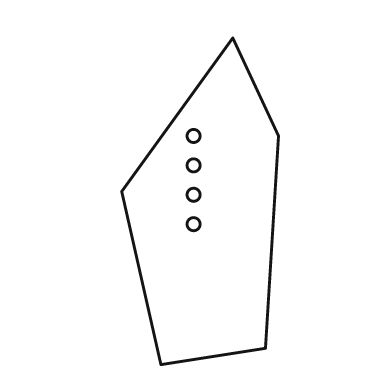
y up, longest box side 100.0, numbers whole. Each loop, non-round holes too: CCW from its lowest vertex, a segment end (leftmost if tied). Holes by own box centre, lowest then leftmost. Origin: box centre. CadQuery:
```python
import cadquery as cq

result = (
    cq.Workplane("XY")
    .moveTo(-12.0, -50.0)
    .lineTo(20.0, -45.0)
    .lineTo(24.0, 20.0)
    .lineTo(10.0, 50.0)
    .lineTo(-24.0, 3.0)
    .close()
    .moveTo(-2.0, -7.0)
    .circle(2.0)
    .moveTo(-2.0, 2.0)
    .circle(2.0)
    .moveTo(-2.0, 11.0)
    .circle(2.0)
    .moveTo(-2.0, 20.0)
    .circle(2.0)
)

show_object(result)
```